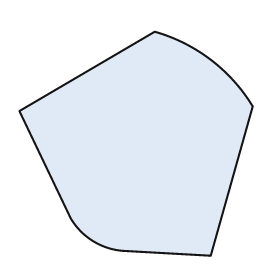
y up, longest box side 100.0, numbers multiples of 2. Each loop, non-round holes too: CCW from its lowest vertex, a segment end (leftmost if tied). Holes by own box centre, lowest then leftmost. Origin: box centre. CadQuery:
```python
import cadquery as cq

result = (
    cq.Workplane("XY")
    .moveTo(32.0, -48.0)
    .lineTo(50.0, 16.0)
    .threePointArc((32.0, 36.0), (8.0, 48.0))
    .lineTo(-50.0, 14.0)
    .lineTo(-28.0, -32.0)
    .threePointArc((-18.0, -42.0), (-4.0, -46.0))
    .close()
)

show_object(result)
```